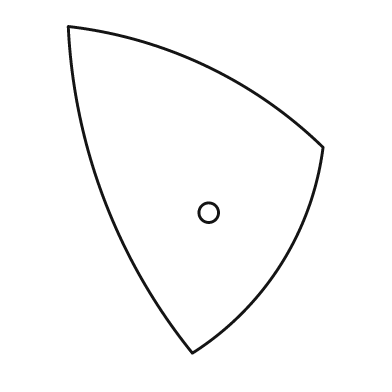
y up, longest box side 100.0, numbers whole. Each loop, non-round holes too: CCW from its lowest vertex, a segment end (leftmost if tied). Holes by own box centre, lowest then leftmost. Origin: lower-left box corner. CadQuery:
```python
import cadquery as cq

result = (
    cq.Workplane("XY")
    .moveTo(38.0, 0.0)
    .threePointArc((65.0, 27.0), (78.0, 63.0))
    .threePointArc((42.0, 88.0), (0.0, 100.0))
    .threePointArc((11.0, 47.0), (38.0, 0.0))
    .close()
    .moveTo(43.0, 43.0)
    .circle(3.0)
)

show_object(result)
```